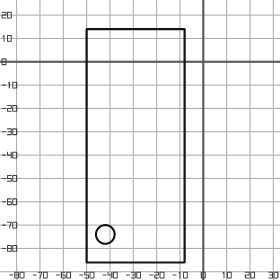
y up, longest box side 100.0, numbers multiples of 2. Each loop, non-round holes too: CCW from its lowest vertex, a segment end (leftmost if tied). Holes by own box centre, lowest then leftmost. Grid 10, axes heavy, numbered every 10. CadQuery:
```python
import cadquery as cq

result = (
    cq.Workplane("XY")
    .moveTo(-50.0, -86.0)
    .lineTo(-8.0, -86.0)
    .lineTo(-8.0, 14.0)
    .lineTo(-50.0, 14.0)
    .close()
    .moveTo(-42.0, -74.0)
    .circle(4.0)
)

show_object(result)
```